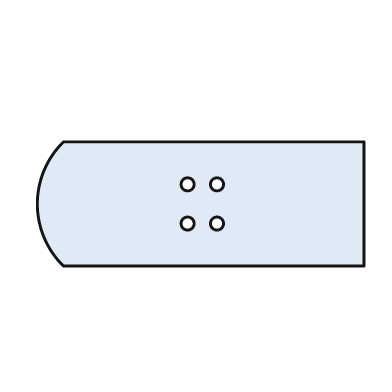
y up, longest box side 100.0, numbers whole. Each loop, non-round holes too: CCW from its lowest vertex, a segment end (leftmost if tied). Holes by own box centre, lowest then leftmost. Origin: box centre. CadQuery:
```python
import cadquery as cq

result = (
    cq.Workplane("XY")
    .moveTo(-42.0, -19.0)
    .lineTo(50.0, -19.0)
    .lineTo(50.0, 19.0)
    .lineTo(-42.0, 19.0)
    .threePointArc((-50.0, 0.0), (-42.0, -19.0))
    .close()
    .moveTo(-4.0, -6.0)
    .circle(2.0)
    .moveTo(5.0, -6.0)
    .circle(2.0)
    .moveTo(-4.0, 6.0)
    .circle(2.0)
    .moveTo(5.0, 6.0)
    .circle(2.0)
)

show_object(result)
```